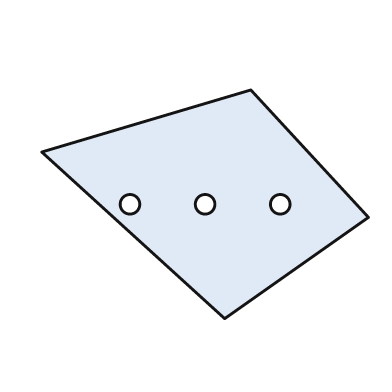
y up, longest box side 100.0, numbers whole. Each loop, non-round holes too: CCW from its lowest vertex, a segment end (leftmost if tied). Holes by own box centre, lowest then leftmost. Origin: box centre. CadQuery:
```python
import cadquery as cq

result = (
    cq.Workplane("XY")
    .moveTo(6.0, -35.0)
    .lineTo(50.0, -4.0)
    .lineTo(14.0, 35.0)
    .lineTo(-50.0, 16.0)
    .close()
    .moveTo(-23.0, 0.0)
    .circle(3.0)
    .moveTo(0.0, 0.0)
    .circle(3.0)
    .moveTo(23.0, 0.0)
    .circle(3.0)
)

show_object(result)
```